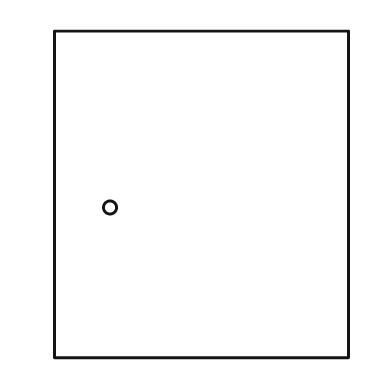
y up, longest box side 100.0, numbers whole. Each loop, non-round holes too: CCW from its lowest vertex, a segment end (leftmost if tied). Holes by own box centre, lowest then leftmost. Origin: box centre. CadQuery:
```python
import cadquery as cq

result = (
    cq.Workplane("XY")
    .moveTo(-45.0, -50.0)
    .lineTo(45.0, -50.0)
    .lineTo(45.0, 50.0)
    .lineTo(-45.0, 50.0)
    .close()
    .moveTo(-28.0, -4.0)
    .circle(2.0)
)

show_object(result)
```